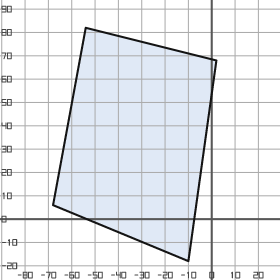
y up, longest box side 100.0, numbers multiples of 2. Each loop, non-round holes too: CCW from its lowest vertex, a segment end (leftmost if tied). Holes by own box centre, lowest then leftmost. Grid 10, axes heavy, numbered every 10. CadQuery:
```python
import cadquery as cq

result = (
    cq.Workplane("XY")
    .moveTo(-10.0, -18.0)
    .lineTo(2.0, 68.0)
    .lineTo(-54.0, 82.0)
    .lineTo(-68.0, 6.0)
    .close()
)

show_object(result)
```